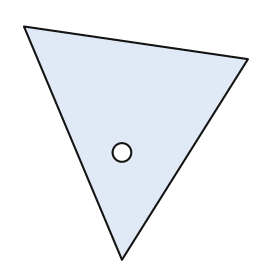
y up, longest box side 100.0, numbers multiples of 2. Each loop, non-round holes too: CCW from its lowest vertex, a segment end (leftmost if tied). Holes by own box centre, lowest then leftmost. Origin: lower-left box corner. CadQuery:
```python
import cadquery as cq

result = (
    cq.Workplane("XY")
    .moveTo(42.0, 0.0)
    .lineTo(96.0, 86.0)
    .lineTo(0.0, 100.0)
    .close()
    .moveTo(42.0, 46.0)
    .circle(4.0)
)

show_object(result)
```